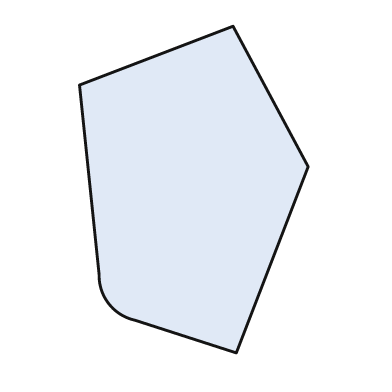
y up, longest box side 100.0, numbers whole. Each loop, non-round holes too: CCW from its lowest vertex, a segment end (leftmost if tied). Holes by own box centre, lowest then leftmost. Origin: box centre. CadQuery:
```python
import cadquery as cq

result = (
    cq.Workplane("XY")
    .moveTo(13.0, -50.0)
    .lineTo(35.0, 7.0)
    .lineTo(12.0, 50.0)
    .lineTo(-35.0, 32.0)
    .lineTo(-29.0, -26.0)
    .threePointArc((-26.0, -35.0), (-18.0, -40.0))
    .close()
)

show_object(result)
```